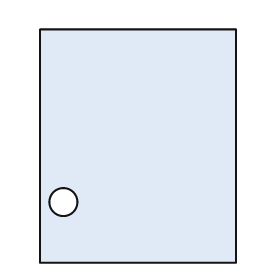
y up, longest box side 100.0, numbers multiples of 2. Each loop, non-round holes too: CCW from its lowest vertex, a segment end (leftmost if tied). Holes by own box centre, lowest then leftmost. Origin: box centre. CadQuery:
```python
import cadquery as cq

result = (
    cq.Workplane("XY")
    .moveTo(-42.0, -50.0)
    .lineTo(42.0, -50.0)
    .lineTo(42.0, 50.0)
    .lineTo(-42.0, 50.0)
    .close()
    .moveTo(-32.0, -24.0)
    .circle(6.0)
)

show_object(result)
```